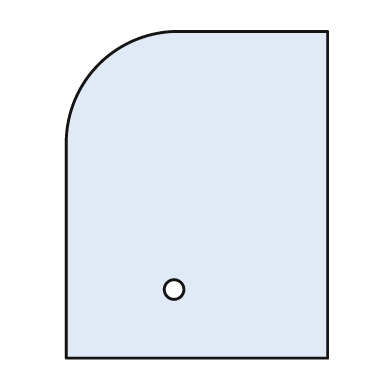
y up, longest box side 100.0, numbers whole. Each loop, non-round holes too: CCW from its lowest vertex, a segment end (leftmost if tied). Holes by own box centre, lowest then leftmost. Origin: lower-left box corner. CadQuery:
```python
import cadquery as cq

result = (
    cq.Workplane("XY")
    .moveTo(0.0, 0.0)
    .lineTo(80.0, 0.0)
    .lineTo(80.0, 100.0)
    .lineTo(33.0, 100.0)
    .threePointArc((10.0, 90.0), (0.0, 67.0))
    .close()
    .moveTo(33.0, 21.0)
    .circle(3.0)
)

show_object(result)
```